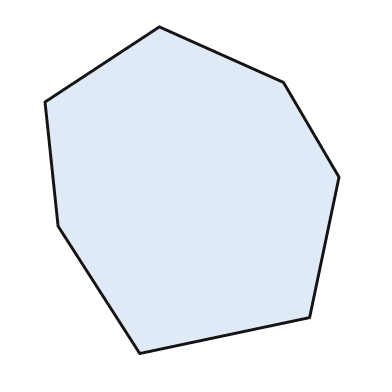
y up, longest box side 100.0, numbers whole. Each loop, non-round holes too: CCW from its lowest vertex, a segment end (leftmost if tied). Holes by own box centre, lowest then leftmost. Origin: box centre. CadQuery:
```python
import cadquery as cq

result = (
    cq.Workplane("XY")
    .moveTo(-16.0, -50.0)
    .lineTo(36.0, -39.0)
    .lineTo(45.0, 4.0)
    .lineTo(28.0, 33.0)
    .lineTo(-10.0, 50.0)
    .lineTo(-45.0, 27.0)
    .lineTo(-41.0, -11.0)
    .close()
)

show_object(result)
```